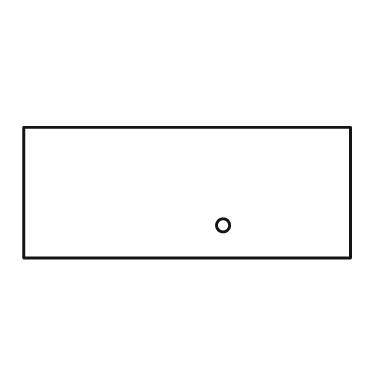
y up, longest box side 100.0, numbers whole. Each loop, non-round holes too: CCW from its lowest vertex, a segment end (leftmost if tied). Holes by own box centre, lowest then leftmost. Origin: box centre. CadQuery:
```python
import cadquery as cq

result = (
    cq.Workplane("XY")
    .moveTo(-50.0, -20.0)
    .lineTo(50.0, -20.0)
    .lineTo(50.0, 20.0)
    .lineTo(-50.0, 20.0)
    .close()
    .moveTo(11.0, -10.0)
    .circle(2.0)
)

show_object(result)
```